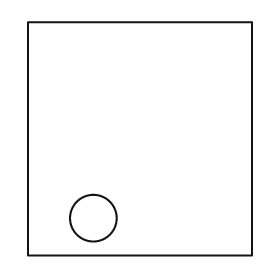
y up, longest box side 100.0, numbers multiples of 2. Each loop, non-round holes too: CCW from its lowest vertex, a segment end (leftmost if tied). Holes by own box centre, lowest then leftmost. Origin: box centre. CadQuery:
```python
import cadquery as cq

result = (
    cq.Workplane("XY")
    .moveTo(-48.0, -50.0)
    .lineTo(48.0, -50.0)
    .lineTo(48.0, 50.0)
    .lineTo(-48.0, 50.0)
    .close()
    .moveTo(-20.0, -34.0)
    .circle(10.0)
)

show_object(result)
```